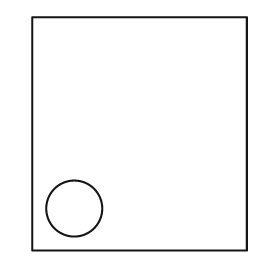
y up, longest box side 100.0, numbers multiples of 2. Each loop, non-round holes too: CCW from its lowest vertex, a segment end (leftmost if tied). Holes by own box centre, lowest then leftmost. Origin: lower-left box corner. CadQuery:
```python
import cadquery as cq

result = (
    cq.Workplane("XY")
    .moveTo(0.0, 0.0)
    .lineTo(92.0, 0.0)
    .lineTo(92.0, 100.0)
    .lineTo(0.0, 100.0)
    .close()
    .moveTo(18.0, 18.0)
    .circle(12.0)
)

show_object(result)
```